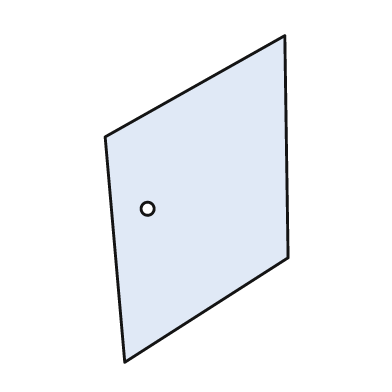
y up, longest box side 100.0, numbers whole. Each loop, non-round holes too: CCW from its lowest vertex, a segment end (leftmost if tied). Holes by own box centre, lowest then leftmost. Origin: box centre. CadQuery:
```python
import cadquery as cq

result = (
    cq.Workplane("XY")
    .moveTo(-22.0, -50.0)
    .lineTo(28.0, -18.0)
    .lineTo(27.0, 50.0)
    .lineTo(-28.0, 19.0)
    .close()
    .moveTo(-15.0, -3.0)
    .circle(2.0)
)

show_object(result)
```